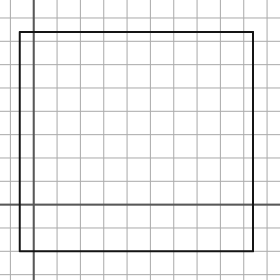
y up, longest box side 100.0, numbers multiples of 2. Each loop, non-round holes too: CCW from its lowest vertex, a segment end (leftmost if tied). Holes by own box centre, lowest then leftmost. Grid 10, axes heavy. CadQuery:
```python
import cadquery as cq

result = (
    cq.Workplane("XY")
    .moveTo(-6.0, -20.0)
    .lineTo(94.0, -20.0)
    .lineTo(94.0, 74.0)
    .lineTo(-6.0, 74.0)
    .close()
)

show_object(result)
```